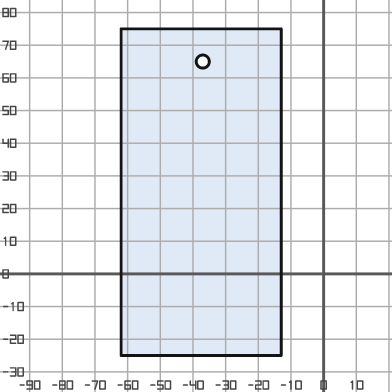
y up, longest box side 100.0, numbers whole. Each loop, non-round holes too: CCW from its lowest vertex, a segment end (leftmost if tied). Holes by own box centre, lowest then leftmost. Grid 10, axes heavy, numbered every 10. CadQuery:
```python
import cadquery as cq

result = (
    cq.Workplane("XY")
    .moveTo(-62.0, -25.0)
    .lineTo(-13.0, -25.0)
    .lineTo(-13.0, 75.0)
    .lineTo(-62.0, 75.0)
    .close()
    .moveTo(-37.0, 65.0)
    .circle(2.0)
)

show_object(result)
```